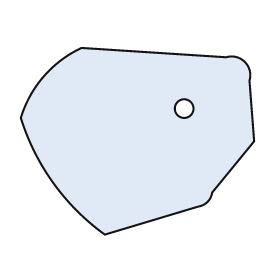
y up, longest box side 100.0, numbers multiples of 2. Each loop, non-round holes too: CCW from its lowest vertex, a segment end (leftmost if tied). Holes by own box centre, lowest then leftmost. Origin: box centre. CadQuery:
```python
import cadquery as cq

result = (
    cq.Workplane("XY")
    .moveTo(-14.0, -40.0)
    .lineTo(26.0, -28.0)
    .threePointArc((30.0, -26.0), (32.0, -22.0))
    .lineTo(50.0, 0.0)
    .lineTo(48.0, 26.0)
    .threePointArc((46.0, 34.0), (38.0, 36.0))
    .lineTo(-24.0, 40.0)
    .threePointArc((-40.0, 28.0), (-50.0, 10.0))
    .threePointArc((-36.0, -18.0), (-14.0, -40.0))
    .close()
    .moveTo(20.0, 14.0)
    .circle(4.0)
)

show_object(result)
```